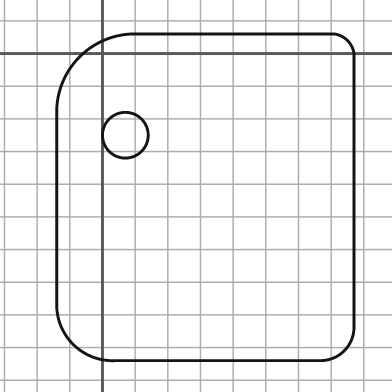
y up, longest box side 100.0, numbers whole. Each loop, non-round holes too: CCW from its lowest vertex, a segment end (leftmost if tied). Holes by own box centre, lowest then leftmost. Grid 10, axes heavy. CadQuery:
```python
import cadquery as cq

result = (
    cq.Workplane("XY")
    .moveTo(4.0, -94.0)
    .lineTo(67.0, -94.0)
    .threePointArc((74.0, -91.0), (77.0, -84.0))
    .lineTo(77.0, 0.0)
    .threePointArc((75.0, 4.0), (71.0, 6.0))
    .lineTo(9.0, 6.0)
    .threePointArc((-7.0, -1.0), (-14.0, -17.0))
    .lineTo(-14.0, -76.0)
    .threePointArc((-9.0, -89.0), (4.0, -94.0))
    .close()
    .moveTo(7.0, -25.0)
    .circle(7.0)
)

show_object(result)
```